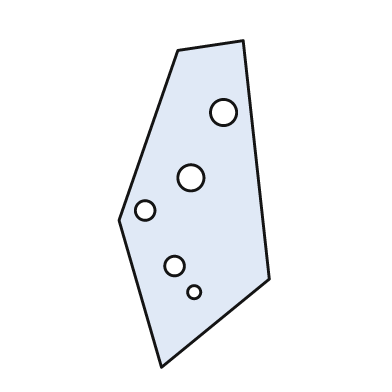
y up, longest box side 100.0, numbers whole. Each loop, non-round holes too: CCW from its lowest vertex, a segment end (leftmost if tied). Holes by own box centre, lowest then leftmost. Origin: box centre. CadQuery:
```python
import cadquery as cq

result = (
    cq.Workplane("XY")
    .moveTo(-10.0, -50.0)
    .lineTo(23.0, -23.0)
    .lineTo(15.0, 50.0)
    .lineTo(-5.0, 47.0)
    .lineTo(-23.0, -5.0)
    .close()
    .moveTo(0.0, -27.0)
    .circle(2.0)
    .moveTo(-6.0, -19.0)
    .circle(3.0)
    .moveTo(-15.0, -2.0)
    .circle(3.0)
    .moveTo(-1.0, 8.0)
    .circle(4.0)
    .moveTo(9.0, 28.0)
    .circle(4.0)
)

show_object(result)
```